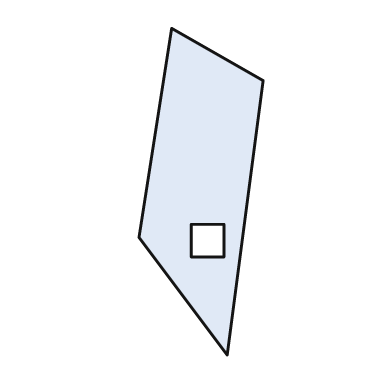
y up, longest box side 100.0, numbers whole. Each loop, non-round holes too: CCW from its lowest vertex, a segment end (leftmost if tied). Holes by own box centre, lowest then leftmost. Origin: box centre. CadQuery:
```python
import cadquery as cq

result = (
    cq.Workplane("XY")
    .moveTo(8.0, -50.0)
    .lineTo(19.0, 34.0)
    .lineTo(-9.0, 50.0)
    .lineTo(-19.0, -14.0)
    .close()
    .moveTo(-3.0, -20.0)
    .lineTo(7.0, -20.0)
    .lineTo(7.0, -10.0)
    .lineTo(-3.0, -10.0)
    .close()
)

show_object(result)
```